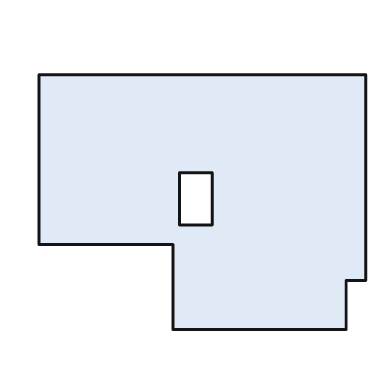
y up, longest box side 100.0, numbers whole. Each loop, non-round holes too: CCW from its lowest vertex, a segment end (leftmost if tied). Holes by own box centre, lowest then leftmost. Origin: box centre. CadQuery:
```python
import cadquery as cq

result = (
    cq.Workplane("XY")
    .moveTo(-9.0, -39.0)
    .lineTo(44.0, -39.0)
    .lineTo(44.0, -24.0)
    .lineTo(50.0, -24.0)
    .lineTo(50.0, 39.0)
    .lineTo(-50.0, 39.0)
    .lineTo(-50.0, -13.0)
    .lineTo(-9.0, -13.0)
    .close()
    .moveTo(-7.0, -7.0)
    .lineTo(3.0, -7.0)
    .lineTo(3.0, 9.0)
    .lineTo(-7.0, 9.0)
    .close()
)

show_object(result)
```